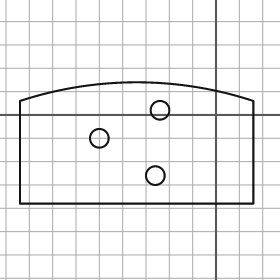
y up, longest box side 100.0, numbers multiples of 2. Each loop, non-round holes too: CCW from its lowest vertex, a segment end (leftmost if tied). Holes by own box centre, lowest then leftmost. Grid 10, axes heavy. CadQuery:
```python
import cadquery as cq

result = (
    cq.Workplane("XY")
    .moveTo(-84.0, -38.0)
    .lineTo(16.0, -38.0)
    .lineTo(16.0, 6.0)
    .threePointArc((-34.0, 14.0), (-84.0, 6.0))
    .close()
    .moveTo(-26.0, -26.0)
    .circle(4.0)
    .moveTo(-50.0, -10.0)
    .circle(4.0)
    .moveTo(-24.0, 2.0)
    .circle(4.0)
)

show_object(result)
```